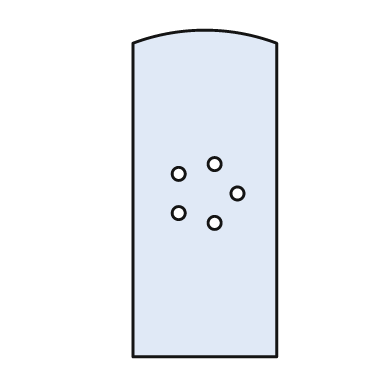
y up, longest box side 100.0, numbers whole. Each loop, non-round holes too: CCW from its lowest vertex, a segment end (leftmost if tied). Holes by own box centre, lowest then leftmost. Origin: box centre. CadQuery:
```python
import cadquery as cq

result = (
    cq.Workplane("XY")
    .moveTo(-22.0, -50.0)
    .lineTo(22.0, -50.0)
    .lineTo(22.0, 46.0)
    .threePointArc((0.0, 50.0), (-22.0, 46.0))
    .close()
    .moveTo(3.0, -9.0)
    .circle(2.0)
    .moveTo(-8.0, -6.0)
    .circle(2.0)
    .moveTo(10.0, 0.0)
    .circle(2.0)
    .moveTo(-8.0, 6.0)
    .circle(2.0)
    .moveTo(3.0, 9.0)
    .circle(2.0)
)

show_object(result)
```